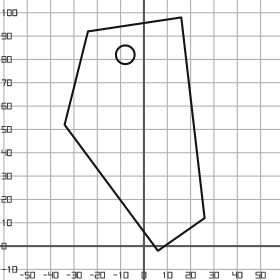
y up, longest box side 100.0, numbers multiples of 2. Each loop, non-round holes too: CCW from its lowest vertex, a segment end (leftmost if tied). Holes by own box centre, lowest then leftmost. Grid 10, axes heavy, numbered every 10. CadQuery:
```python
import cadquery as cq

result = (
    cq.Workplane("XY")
    .moveTo(6.0, -2.0)
    .lineTo(26.0, 12.0)
    .lineTo(16.0, 98.0)
    .lineTo(-24.0, 92.0)
    .lineTo(-34.0, 52.0)
    .close()
    .moveTo(-8.0, 82.0)
    .circle(4.0)
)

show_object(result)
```